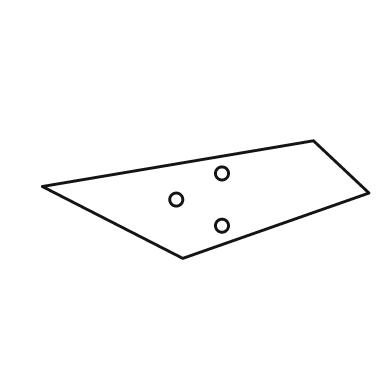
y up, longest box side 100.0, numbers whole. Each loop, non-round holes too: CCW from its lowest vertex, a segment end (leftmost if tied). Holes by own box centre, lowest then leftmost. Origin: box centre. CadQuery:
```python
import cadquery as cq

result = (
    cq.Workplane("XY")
    .moveTo(-7.0, -18.0)
    .lineTo(50.0, 2.0)
    .lineTo(33.0, 18.0)
    .lineTo(-50.0, 4.0)
    .close()
    .moveTo(5.0, -8.0)
    .circle(2.0)
    .moveTo(-9.0, 0.0)
    .circle(2.0)
    .moveTo(5.0, 8.0)
    .circle(2.0)
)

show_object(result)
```